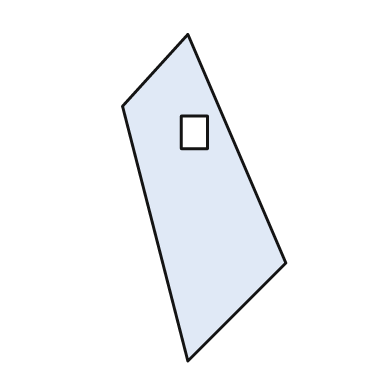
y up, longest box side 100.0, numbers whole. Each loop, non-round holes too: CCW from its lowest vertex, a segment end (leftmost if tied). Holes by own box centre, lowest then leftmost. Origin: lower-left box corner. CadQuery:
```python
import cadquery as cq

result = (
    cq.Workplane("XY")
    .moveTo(20.0, 0.0)
    .lineTo(50.0, 30.0)
    .lineTo(20.0, 100.0)
    .lineTo(0.0, 78.0)
    .close()
    .moveTo(18.0, 65.0)
    .lineTo(26.0, 65.0)
    .lineTo(26.0, 75.0)
    .lineTo(18.0, 75.0)
    .close()
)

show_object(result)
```